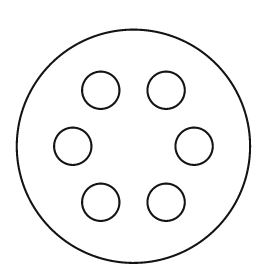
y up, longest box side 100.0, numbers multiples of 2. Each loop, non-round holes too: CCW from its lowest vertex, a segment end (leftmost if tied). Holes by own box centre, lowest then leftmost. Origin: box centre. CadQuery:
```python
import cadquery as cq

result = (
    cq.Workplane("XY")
    .moveTo(0.0, 0.0)
    .circle(50.0)
    .moveTo(-14.0, -24.0)
    .circle(8.0)
    .moveTo(14.0, -24.0)
    .circle(8.0)
    .moveTo(-26.0, 0.0)
    .circle(8.0)
    .moveTo(26.0, 0.0)
    .circle(8.0)
    .moveTo(-14.0, 24.0)
    .circle(8.0)
    .moveTo(14.0, 24.0)
    .circle(8.0)
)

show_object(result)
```